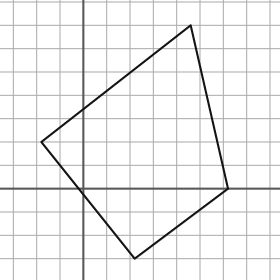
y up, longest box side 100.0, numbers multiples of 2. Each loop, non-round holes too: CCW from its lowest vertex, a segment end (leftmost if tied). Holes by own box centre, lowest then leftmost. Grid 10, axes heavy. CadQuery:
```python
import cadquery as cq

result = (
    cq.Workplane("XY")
    .moveTo(22.0, -30.0)
    .lineTo(62.0, 0.0)
    .lineTo(46.0, 70.0)
    .lineTo(-18.0, 20.0)
    .close()
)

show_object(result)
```